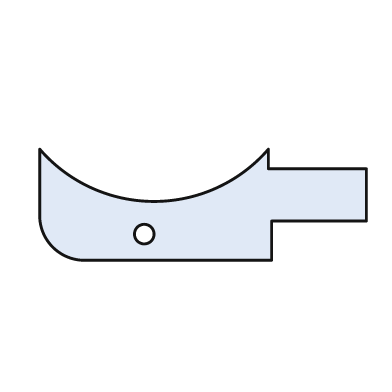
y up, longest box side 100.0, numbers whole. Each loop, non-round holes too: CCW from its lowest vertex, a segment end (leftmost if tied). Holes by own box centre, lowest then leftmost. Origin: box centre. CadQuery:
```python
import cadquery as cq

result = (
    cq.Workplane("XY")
    .moveTo(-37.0, -17.0)
    .lineTo(21.0, -17.0)
    .lineTo(21.0, -5.0)
    .lineTo(50.0, -5.0)
    .lineTo(50.0, 11.0)
    .lineTo(20.0, 11.0)
    .lineTo(20.0, 17.0)
    .threePointArc((-15.0, 1.0), (-50.0, 17.0))
    .lineTo(-50.0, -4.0)
    .threePointArc((-46.0, -13.0), (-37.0, -17.0))
    .close()
    .moveTo(-18.0, -9.0)
    .circle(3.0)
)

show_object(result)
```